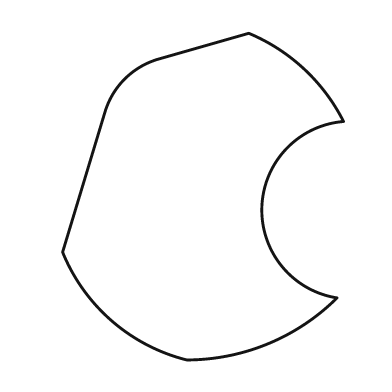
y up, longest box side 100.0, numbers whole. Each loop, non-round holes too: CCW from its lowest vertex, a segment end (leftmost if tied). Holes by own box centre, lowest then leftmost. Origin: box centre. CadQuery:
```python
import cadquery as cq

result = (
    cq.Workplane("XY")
    .moveTo(-5.0, -50.0)
    .threePointArc((20.0, -45.0), (41.0, -31.0))
    .threePointArc((18.0, -3.0), (43.0, 23.0))
    .threePointArc((31.0, 39.0), (14.0, 50.0))
    .lineTo(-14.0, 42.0)
    .threePointArc((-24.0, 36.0), (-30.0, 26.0))
    .lineTo(-43.0, -17.0)
    .threePointArc((-28.0, -38.0), (-5.0, -50.0))
    .close()
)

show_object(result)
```